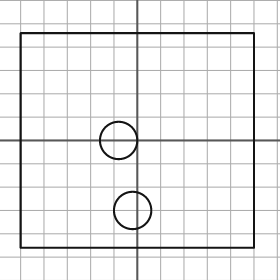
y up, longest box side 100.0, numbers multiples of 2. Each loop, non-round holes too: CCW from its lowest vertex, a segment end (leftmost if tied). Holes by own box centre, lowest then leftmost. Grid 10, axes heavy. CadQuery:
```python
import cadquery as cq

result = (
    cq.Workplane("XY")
    .moveTo(-50.0, -46.0)
    .lineTo(50.0, -46.0)
    .lineTo(50.0, 46.0)
    .lineTo(-50.0, 46.0)
    .close()
    .moveTo(-2.0, -30.0)
    .circle(8.0)
    .moveTo(-8.0, 0.0)
    .circle(8.0)
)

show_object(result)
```